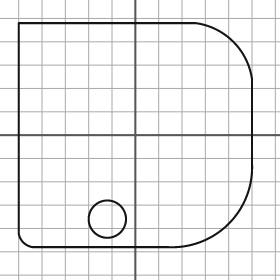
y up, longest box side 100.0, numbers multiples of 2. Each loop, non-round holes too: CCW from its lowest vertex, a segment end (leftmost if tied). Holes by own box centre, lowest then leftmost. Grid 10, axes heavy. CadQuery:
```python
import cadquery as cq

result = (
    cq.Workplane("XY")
    .moveTo(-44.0, -48.0)
    .lineTo(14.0, -48.0)
    .threePointArc((40.0, -38.0), (50.0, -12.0))
    .lineTo(50.0, 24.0)
    .threePointArc((42.0, 40.0), (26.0, 48.0))
    .lineTo(-50.0, 48.0)
    .lineTo(-50.0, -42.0)
    .threePointArc((-48.0, -46.0), (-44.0, -48.0))
    .close()
    .moveTo(-12.0, -36.0)
    .circle(8.0)
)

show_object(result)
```